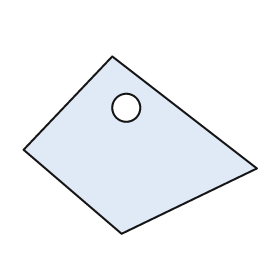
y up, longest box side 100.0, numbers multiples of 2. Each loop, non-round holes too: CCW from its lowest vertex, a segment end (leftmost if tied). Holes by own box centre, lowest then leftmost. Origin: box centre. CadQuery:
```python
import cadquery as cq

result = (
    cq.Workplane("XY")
    .moveTo(-8.0, -38.0)
    .lineTo(50.0, -10.0)
    .lineTo(-12.0, 38.0)
    .lineTo(-50.0, -2.0)
    .close()
    .moveTo(-6.0, 16.0)
    .circle(6.0)
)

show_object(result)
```